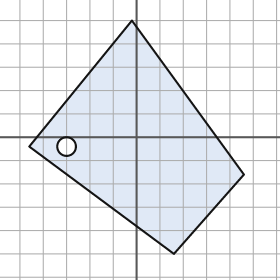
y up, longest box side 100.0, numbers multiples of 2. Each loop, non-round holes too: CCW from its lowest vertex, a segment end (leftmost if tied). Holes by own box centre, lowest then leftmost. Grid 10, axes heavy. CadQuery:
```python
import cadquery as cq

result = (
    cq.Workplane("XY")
    .moveTo(16.0, -50.0)
    .lineTo(46.0, -16.0)
    .lineTo(-2.0, 50.0)
    .lineTo(-46.0, -4.0)
    .close()
    .moveTo(-30.0, -4.0)
    .circle(4.0)
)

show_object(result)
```